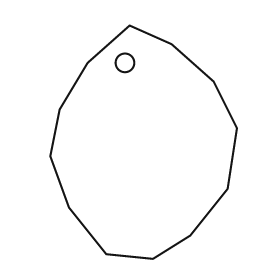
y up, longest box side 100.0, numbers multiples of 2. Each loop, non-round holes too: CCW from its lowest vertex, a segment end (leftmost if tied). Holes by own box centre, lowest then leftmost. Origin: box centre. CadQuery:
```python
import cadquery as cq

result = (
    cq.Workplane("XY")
    .moveTo(4.0, -50.0)
    .lineTo(20.0, -40.0)
    .lineTo(36.0, -20.0)
    .lineTo(40.0, 6.0)
    .lineTo(30.0, 26.0)
    .lineTo(12.0, 42.0)
    .lineTo(-6.0, 50.0)
    .lineTo(-24.0, 34.0)
    .lineTo(-36.0, 14.0)
    .lineTo(-40.0, -6.0)
    .lineTo(-32.0, -28.0)
    .lineTo(-16.0, -48.0)
    .close()
    .moveTo(-8.0, 34.0)
    .circle(4.0)
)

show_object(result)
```